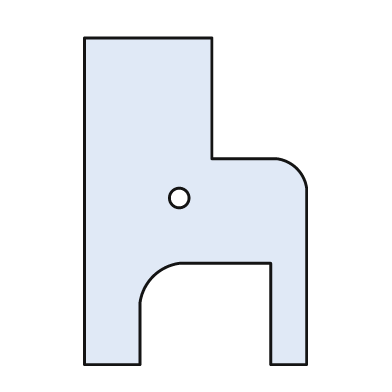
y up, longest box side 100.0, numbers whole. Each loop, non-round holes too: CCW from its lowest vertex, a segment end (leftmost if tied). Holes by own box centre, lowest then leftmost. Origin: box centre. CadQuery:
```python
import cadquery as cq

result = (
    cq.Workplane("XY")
    .moveTo(-34.0, -50.0)
    .lineTo(-17.0, -50.0)
    .lineTo(-17.0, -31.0)
    .threePointArc((-13.0, -23.0), (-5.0, -19.0))
    .lineTo(23.0, -19.0)
    .lineTo(23.0, -50.0)
    .lineTo(34.0, -50.0)
    .lineTo(34.0, 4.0)
    .threePointArc((31.0, 10.0), (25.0, 13.0))
    .lineTo(5.0, 13.0)
    .lineTo(5.0, 50.0)
    .lineTo(-34.0, 50.0)
    .close()
    .moveTo(-5.0, 1.0)
    .circle(3.0)
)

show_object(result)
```